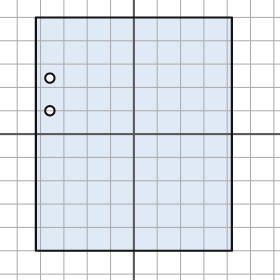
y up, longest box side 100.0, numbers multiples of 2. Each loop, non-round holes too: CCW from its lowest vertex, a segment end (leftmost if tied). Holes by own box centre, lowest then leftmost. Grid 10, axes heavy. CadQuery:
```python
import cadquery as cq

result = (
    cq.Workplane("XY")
    .moveTo(-42.0, -50.0)
    .lineTo(42.0, -50.0)
    .lineTo(42.0, 50.0)
    .lineTo(-42.0, 50.0)
    .close()
    .moveTo(-36.0, 10.0)
    .circle(2.0)
    .moveTo(-36.0, 24.0)
    .circle(2.0)
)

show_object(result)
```